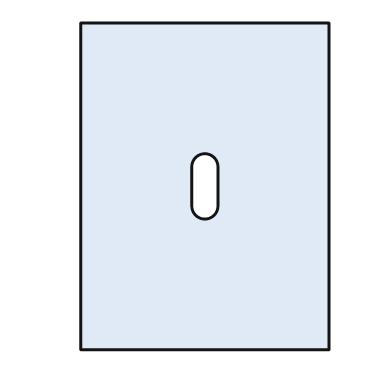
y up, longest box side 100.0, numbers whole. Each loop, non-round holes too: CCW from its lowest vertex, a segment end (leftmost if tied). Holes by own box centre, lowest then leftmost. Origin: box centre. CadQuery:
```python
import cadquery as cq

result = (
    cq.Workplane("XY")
    .moveTo(-38.0, -50.0)
    .lineTo(38.0, -50.0)
    .lineTo(38.0, 50.0)
    .lineTo(-38.0, 50.0)
    .close()
    .moveTo(-4.0, -6.0)
    .threePointArc((0.0, -10.0), (4.0, -6.0))
    .lineTo(4.0, 6.0)
    .threePointArc((0.0, 10.0), (-4.0, 6.0))
    .close()
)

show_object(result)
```